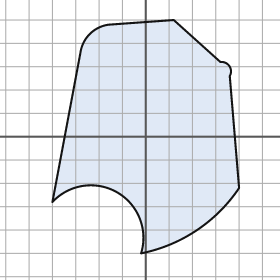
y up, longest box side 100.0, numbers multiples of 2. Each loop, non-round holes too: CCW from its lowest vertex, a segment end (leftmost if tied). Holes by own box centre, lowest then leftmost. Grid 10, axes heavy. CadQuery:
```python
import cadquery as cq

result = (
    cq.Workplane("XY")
    .moveTo(-2.0, -50.0)
    .threePointArc((22.0, -40.0), (40.0, -22.0))
    .lineTo(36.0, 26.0)
    .threePointArc((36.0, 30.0), (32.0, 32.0))
    .lineTo(12.0, 50.0)
    .lineTo(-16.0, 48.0)
    .threePointArc((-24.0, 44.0), (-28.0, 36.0))
    .lineTo(-40.0, -28.0)
    .threePointArc((-12.0, -24.0), (-2.0, -50.0))
    .close()
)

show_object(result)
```